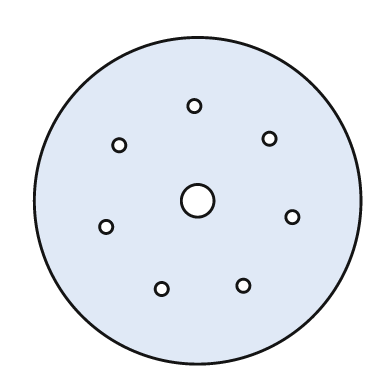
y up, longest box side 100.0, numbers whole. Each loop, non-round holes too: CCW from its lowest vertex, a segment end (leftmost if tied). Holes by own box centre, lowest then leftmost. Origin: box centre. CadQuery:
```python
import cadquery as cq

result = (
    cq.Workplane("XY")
    .moveTo(0.0, 0.0)
    .circle(50.0)
    .moveTo(-11.0, -27.0)
    .circle(2.0)
    .moveTo(14.0, -26.0)
    .circle(2.0)
    .moveTo(-28.0, -8.0)
    .circle(2.0)
    .moveTo(29.0, -5.0)
    .circle(2.0)
    .moveTo(0.0, 0.0)
    .circle(5.0)
    .moveTo(-24.0, 17.0)
    .circle(2.0)
    .moveTo(22.0, 19.0)
    .circle(2.0)
    .moveTo(-1.0, 29.0)
    .circle(2.0)
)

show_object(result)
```